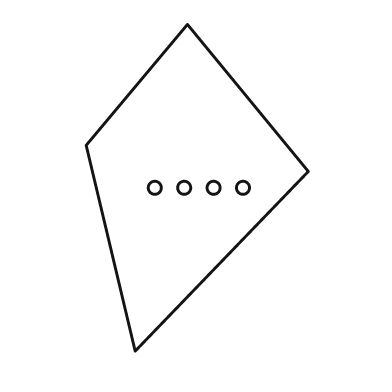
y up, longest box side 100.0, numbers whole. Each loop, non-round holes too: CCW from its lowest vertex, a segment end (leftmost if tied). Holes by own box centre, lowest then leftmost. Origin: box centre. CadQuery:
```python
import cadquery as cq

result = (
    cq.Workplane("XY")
    .moveTo(-19.0, -50.0)
    .lineTo(34.0, 5.0)
    .lineTo(-3.0, 50.0)
    .lineTo(-34.0, 13.0)
    .close()
    .moveTo(-13.0, 0.0)
    .circle(2.0)
    .moveTo(-4.0, 0.0)
    .circle(2.0)
    .moveTo(5.0, 0.0)
    .circle(2.0)
    .moveTo(14.0, 0.0)
    .circle(2.0)
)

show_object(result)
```